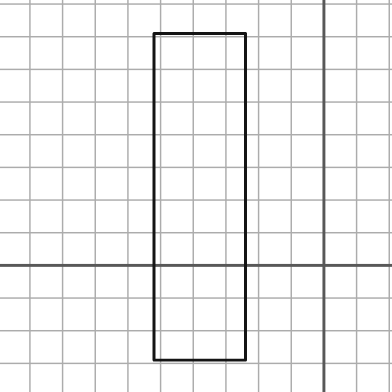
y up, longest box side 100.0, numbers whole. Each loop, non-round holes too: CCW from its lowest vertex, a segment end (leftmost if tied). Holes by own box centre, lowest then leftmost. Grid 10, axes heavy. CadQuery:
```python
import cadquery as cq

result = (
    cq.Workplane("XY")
    .moveTo(-52.0, -29.0)
    .lineTo(-24.0, -29.0)
    .lineTo(-24.0, 71.0)
    .lineTo(-52.0, 71.0)
    .close()
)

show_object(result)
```